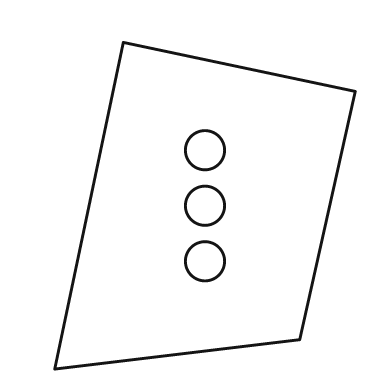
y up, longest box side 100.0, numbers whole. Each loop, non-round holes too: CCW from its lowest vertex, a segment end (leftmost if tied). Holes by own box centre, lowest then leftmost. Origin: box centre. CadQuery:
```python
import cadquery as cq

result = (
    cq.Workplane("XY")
    .moveTo(-46.0, -50.0)
    .lineTo(29.0, -41.0)
    .lineTo(46.0, 35.0)
    .lineTo(-25.0, 50.0)
    .close()
    .moveTo(0.0, -17.0)
    .circle(6.0)
    .moveTo(0.0, 0.0)
    .circle(6.0)
    .moveTo(0.0, 17.0)
    .circle(6.0)
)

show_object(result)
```